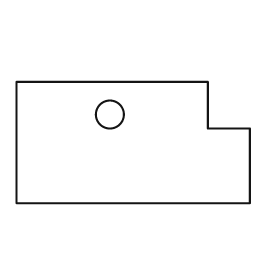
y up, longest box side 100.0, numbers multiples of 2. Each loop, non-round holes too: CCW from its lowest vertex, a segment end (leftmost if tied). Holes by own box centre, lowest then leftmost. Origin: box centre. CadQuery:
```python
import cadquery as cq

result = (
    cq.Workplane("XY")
    .moveTo(-50.0, -26.0)
    .lineTo(50.0, -26.0)
    .lineTo(50.0, 6.0)
    .lineTo(32.0, 6.0)
    .lineTo(32.0, 26.0)
    .lineTo(-50.0, 26.0)
    .close()
    .moveTo(-10.0, 12.0)
    .circle(6.0)
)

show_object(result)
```